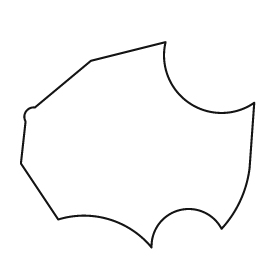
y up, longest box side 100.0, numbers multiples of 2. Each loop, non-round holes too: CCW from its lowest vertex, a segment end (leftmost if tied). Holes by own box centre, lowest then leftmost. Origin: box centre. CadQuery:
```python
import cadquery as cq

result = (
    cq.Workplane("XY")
    .moveTo(6.0, -44.0)
    .threePointArc((18.0, -28.0), (36.0, -36.0))
    .threePointArc((44.0, -24.0), (48.0, -10.0))
    .lineTo(50.0, 18.0)
    .threePointArc((22.0, 18.0), (12.0, 44.0))
    .lineTo(-20.0, 36.0)
    .lineTo(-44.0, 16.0)
    .threePointArc((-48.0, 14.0), (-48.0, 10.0))
    .lineTo(-50.0, -8.0)
    .lineTo(-34.0, -32.0)
    .threePointArc((-12.0, -32.0), (6.0, -44.0))
    .close()
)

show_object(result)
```